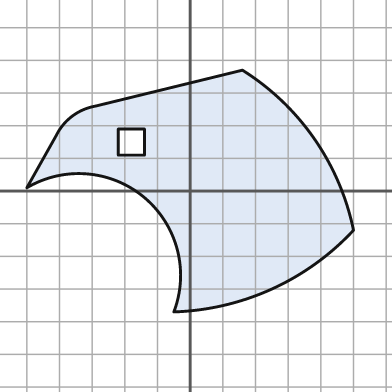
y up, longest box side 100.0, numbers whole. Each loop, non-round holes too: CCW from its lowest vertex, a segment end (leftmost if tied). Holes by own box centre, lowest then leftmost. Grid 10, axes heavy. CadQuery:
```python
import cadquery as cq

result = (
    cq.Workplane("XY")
    .moveTo(-5.0, -37.0)
    .threePointArc((25.0, -30.0), (50.0, -12.0))
    .threePointArc((38.0, 16.0), (16.0, 37.0))
    .lineTo(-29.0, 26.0)
    .threePointArc((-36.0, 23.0), (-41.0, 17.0))
    .lineTo(-50.0, 1.0)
    .threePointArc((-14.0, -2.0), (-5.0, -37.0))
    .close()
    .moveTo(-22.0, 11.0)
    .lineTo(-14.0, 11.0)
    .lineTo(-14.0, 19.0)
    .lineTo(-22.0, 19.0)
    .close()
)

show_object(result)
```